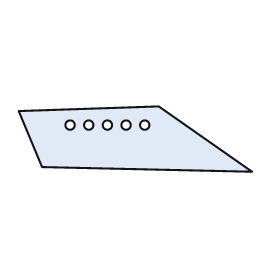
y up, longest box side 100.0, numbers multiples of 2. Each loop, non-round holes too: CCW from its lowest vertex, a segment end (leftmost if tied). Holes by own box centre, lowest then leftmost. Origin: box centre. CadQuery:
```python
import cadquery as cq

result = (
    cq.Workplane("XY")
    .moveTo(50.0, -14.0)
    .lineTo(10.0, 14.0)
    .lineTo(-50.0, 12.0)
    .lineTo(-40.0, -12.0)
    .close()
    .moveTo(-28.0, 6.0)
    .circle(2.0)
    .moveTo(-20.0, 6.0)
    .circle(2.0)
    .moveTo(-12.0, 6.0)
    .circle(2.0)
    .moveTo(-4.0, 6.0)
    .circle(2.0)
    .moveTo(4.0, 6.0)
    .circle(2.0)
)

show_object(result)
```